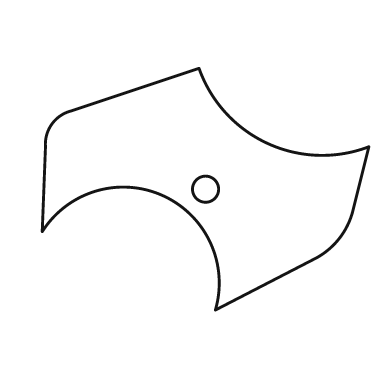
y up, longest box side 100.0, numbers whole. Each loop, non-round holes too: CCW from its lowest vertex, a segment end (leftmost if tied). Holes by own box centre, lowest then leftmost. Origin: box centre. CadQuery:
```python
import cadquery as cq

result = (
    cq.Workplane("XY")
    .moveTo(3.0, -37.0)
    .lineTo(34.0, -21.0)
    .threePointArc((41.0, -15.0), (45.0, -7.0))
    .lineTo(50.0, 13.0)
    .threePointArc((19.0, 14.0), (-2.0, 37.0))
    .lineTo(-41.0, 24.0)
    .threePointArc((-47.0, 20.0), (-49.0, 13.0))
    .lineTo(-50.0, -13.0)
    .threePointArc((-13.0, -2.0), (3.0, -37.0))
    .close()
    .moveTo(0.0, 0.0)
    .circle(4.0)
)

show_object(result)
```